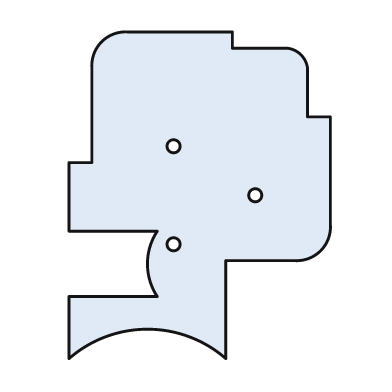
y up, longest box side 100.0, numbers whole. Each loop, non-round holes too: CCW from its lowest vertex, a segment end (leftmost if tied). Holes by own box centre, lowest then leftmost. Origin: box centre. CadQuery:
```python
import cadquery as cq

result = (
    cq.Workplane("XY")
    .moveTo(-40.0, -50.0)
    .threePointArc((-16.0, -41.0), (8.0, -50.0))
    .lineTo(8.0, -20.0)
    .lineTo(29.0, -20.0)
    .threePointArc((37.0, -17.0), (40.0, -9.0))
    .lineTo(40.0, 24.0)
    .lineTo(33.0, 24.0)
    .lineTo(33.0, 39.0)
    .threePointArc((31.0, 43.0), (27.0, 45.0))
    .lineTo(10.0, 45.0)
    .lineTo(10.0, 50.0)
    .lineTo(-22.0, 50.0)
    .threePointArc((-30.0, 47.0), (-33.0, 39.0))
    .lineTo(-33.0, 10.0)
    .lineTo(-40.0, 10.0)
    .lineTo(-40.0, -11.0)
    .lineTo(-13.0, -11.0)
    .threePointArc((-16.0, -21.0), (-13.0, -31.0))
    .lineTo(-40.0, -31.0)
    .close()
    .moveTo(-8.0, -15.0)
    .circle(2.0)
    .moveTo(17.0, 0.0)
    .circle(2.0)
    .moveTo(-8.0, 15.0)
    .circle(2.0)
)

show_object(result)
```